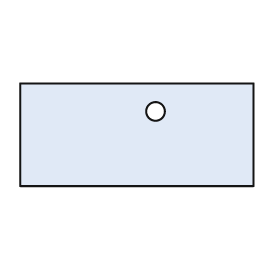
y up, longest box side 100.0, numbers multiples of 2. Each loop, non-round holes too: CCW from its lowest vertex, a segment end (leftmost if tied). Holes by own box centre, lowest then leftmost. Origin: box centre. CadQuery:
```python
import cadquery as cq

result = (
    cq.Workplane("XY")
    .moveTo(-50.0, -22.0)
    .lineTo(50.0, -22.0)
    .lineTo(50.0, 22.0)
    .lineTo(-50.0, 22.0)
    .close()
    .moveTo(8.0, 10.0)
    .circle(4.0)
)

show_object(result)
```